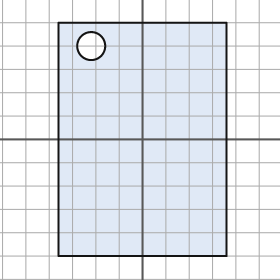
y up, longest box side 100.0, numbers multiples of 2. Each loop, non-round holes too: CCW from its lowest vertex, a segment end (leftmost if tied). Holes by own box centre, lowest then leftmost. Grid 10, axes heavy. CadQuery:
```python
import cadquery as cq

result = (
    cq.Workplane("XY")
    .moveTo(-36.0, -50.0)
    .lineTo(36.0, -50.0)
    .lineTo(36.0, 50.0)
    .lineTo(-36.0, 50.0)
    .close()
    .moveTo(-22.0, 40.0)
    .circle(6.0)
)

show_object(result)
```